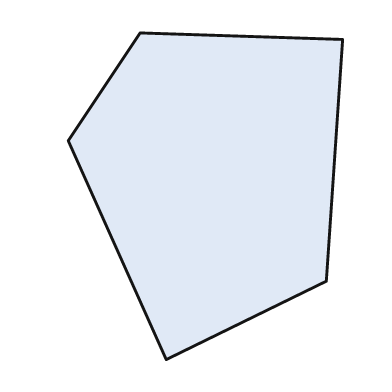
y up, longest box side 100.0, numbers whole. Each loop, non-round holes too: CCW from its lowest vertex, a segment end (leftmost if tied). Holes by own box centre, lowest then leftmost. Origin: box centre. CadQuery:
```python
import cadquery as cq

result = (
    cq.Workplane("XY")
    .moveTo(-12.0, -50.0)
    .lineTo(37.0, -26.0)
    .lineTo(42.0, 48.0)
    .lineTo(-20.0, 50.0)
    .lineTo(-42.0, 17.0)
    .close()
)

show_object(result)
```